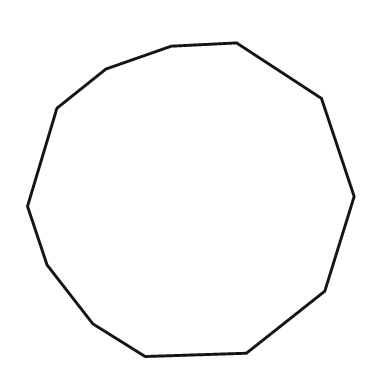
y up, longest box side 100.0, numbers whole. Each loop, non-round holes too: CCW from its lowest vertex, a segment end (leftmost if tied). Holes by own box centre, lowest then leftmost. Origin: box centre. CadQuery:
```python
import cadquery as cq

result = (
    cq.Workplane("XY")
    .moveTo(-14.0, -48.0)
    .lineTo(17.0, -47.0)
    .lineTo(41.0, -28.0)
    .lineTo(50.0, 1.0)
    .lineTo(40.0, 31.0)
    .lineTo(14.0, 48.0)
    .lineTo(-6.0, 47.0)
    .lineTo(-26.0, 40.0)
    .lineTo(-41.0, 28.0)
    .lineTo(-50.0, -2.0)
    .lineTo(-44.0, -20.0)
    .lineTo(-30.0, -38.0)
    .close()
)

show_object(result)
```